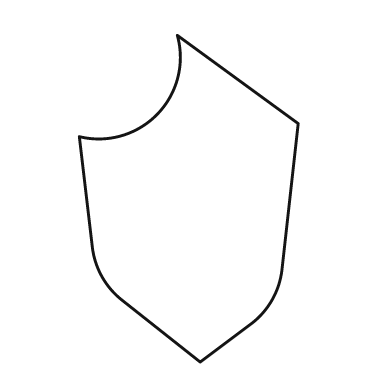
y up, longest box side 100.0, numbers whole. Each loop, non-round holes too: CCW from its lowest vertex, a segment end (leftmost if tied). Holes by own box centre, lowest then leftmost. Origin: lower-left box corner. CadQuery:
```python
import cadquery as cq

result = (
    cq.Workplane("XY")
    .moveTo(37.0, 0.0)
    .lineTo(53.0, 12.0)
    .threePointArc((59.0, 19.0), (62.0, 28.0))
    .lineTo(67.0, 73.0)
    .lineTo(30.0, 100.0)
    .threePointArc((24.0, 76.0), (0.0, 69.0))
    .lineTo(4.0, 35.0)
    .threePointArc((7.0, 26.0), (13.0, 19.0))
    .close()
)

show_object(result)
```